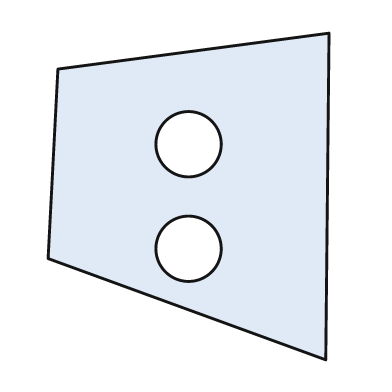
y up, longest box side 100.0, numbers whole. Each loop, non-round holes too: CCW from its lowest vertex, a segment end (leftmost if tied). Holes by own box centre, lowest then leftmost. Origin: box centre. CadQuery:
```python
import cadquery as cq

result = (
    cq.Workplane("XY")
    .moveTo(42.0, -50.0)
    .lineTo(43.0, 50.0)
    .lineTo(-40.0, 39.0)
    .lineTo(-43.0, -19.0)
    .close()
    .moveTo(0.0, -16.0)
    .circle(10.0)
    .moveTo(0.0, 16.0)
    .circle(10.0)
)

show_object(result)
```